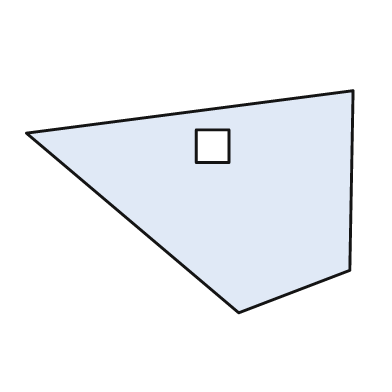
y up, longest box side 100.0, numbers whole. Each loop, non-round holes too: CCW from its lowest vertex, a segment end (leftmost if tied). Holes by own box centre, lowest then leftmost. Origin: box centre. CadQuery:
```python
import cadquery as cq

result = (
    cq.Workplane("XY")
    .moveTo(15.0, -34.0)
    .lineTo(49.0, -21.0)
    .lineTo(50.0, 34.0)
    .lineTo(-50.0, 21.0)
    .close()
    .moveTo(2.0, 12.0)
    .lineTo(12.0, 12.0)
    .lineTo(12.0, 22.0)
    .lineTo(2.0, 22.0)
    .close()
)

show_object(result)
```